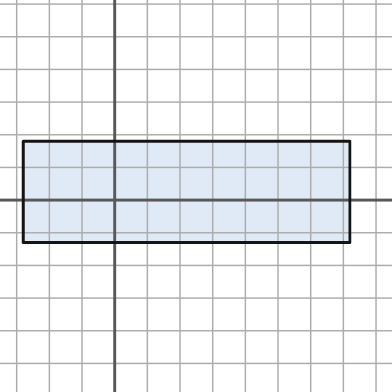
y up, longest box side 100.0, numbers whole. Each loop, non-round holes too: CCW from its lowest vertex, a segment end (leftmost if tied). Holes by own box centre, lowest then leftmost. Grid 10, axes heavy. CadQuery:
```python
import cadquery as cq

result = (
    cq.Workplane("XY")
    .moveTo(-28.0, -13.0)
    .lineTo(72.0, -13.0)
    .lineTo(72.0, 18.0)
    .lineTo(-28.0, 18.0)
    .close()
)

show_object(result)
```